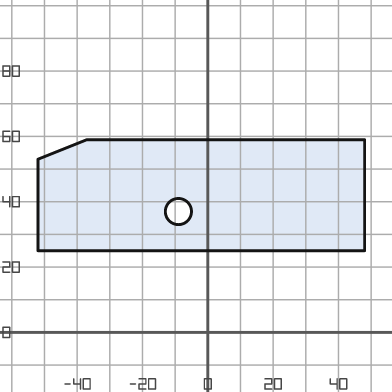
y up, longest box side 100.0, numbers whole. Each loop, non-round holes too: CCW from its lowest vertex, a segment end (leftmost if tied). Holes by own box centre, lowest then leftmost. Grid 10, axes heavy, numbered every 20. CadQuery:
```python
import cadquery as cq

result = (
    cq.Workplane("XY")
    .moveTo(-52.0, 25.0)
    .lineTo(48.0, 25.0)
    .lineTo(48.0, 59.0)
    .lineTo(-37.0, 59.0)
    .lineTo(-52.0, 53.0)
    .close()
    .moveTo(-9.0, 37.0)
    .circle(4.0)
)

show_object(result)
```